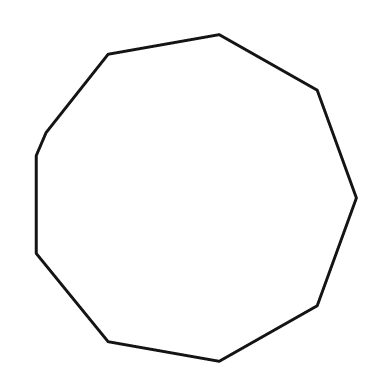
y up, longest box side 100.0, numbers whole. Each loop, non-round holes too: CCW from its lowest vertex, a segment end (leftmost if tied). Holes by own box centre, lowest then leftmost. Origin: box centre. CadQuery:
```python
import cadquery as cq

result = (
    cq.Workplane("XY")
    .moveTo(7.0, -50.0)
    .lineTo(37.0, -33.0)
    .lineTo(49.0, 0.0)
    .lineTo(37.0, 33.0)
    .lineTo(7.0, 50.0)
    .lineTo(-27.0, 44.0)
    .lineTo(-46.0, 20.0)
    .lineTo(-49.0, 13.0)
    .lineTo(-49.0, -17.0)
    .lineTo(-27.0, -44.0)
    .close()
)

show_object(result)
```